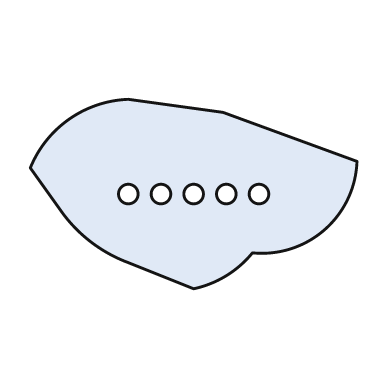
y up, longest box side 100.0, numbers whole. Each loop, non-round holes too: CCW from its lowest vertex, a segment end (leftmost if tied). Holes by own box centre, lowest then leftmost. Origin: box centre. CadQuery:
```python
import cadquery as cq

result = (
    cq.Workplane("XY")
    .moveTo(0.0, -29.0)
    .threePointArc((10.0, -25.0), (18.0, -18.0))
    .threePointArc((40.0, -11.0), (50.0, 10.0))
    .lineTo(9.0, 25.0)
    .lineTo(-20.0, 29.0)
    .threePointArc((-38.0, 23.0), (-50.0, 8.0))
    .lineTo(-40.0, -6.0)
    .threePointArc((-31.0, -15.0), (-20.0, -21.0))
    .close()
    .moveTo(-20.0, 0.0)
    .circle(3.0)
    .moveTo(-10.0, 0.0)
    .circle(3.0)
    .moveTo(0.0, 0.0)
    .circle(3.0)
    .moveTo(10.0, 0.0)
    .circle(3.0)
    .moveTo(20.0, 0.0)
    .circle(3.0)
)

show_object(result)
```